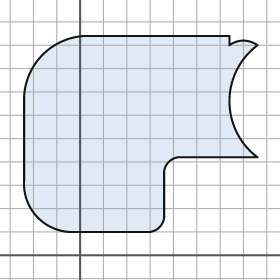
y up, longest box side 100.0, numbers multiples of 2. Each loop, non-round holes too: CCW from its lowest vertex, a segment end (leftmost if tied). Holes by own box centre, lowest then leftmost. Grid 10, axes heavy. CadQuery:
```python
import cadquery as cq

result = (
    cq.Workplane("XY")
    .moveTo(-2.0, 10.0)
    .lineTo(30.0, 10.0)
    .threePointArc((34.0, 12.0), (36.0, 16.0))
    .lineTo(36.0, 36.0)
    .threePointArc((38.0, 40.0), (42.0, 42.0))
    .lineTo(76.0, 42.0)
    .threePointArc((64.0, 66.0), (76.0, 90.0))
    .threePointArc((70.0, 92.0), (64.0, 90.0))
    .lineTo(64.0, 94.0)
    .lineTo(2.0, 94.0)
    .threePointArc((-16.0, 86.0), (-24.0, 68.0))
    .lineTo(-24.0, 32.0)
    .threePointArc((-18.0, 16.0), (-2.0, 10.0))
    .close()
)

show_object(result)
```